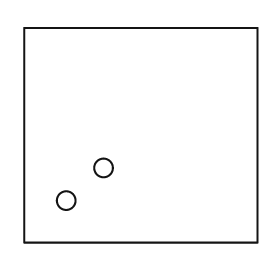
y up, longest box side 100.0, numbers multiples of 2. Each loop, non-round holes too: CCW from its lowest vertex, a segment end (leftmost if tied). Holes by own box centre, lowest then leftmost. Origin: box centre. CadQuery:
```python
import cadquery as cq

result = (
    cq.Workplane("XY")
    .moveTo(-50.0, -46.0)
    .lineTo(50.0, -46.0)
    .lineTo(50.0, 46.0)
    .lineTo(-50.0, 46.0)
    .close()
    .moveTo(-32.0, -28.0)
    .circle(4.0)
    .moveTo(-16.0, -14.0)
    .circle(4.0)
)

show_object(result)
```